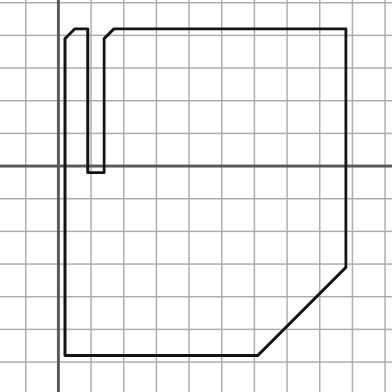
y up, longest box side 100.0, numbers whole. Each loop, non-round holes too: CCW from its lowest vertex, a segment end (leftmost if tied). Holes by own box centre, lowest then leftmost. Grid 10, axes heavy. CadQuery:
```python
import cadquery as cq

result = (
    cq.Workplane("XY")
    .moveTo(2.0, -58.0)
    .lineTo(61.0, -58.0)
    .lineTo(88.0, -31.0)
    .lineTo(88.0, 42.0)
    .lineTo(17.0, 42.0)
    .lineTo(14.0, 39.0)
    .lineTo(14.0, -2.0)
    .lineTo(9.0, -2.0)
    .lineTo(9.0, 42.0)
    .lineTo(5.0, 42.0)
    .lineTo(2.0, 39.0)
    .close()
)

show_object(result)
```